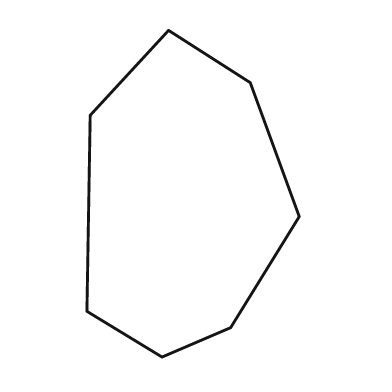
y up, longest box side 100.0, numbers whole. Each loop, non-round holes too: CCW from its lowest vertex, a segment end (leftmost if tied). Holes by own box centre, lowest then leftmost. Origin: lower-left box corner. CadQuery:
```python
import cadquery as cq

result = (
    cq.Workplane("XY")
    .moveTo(23.0, 0.0)
    .lineTo(44.0, 9.0)
    .lineTo(65.0, 43.0)
    .lineTo(50.0, 84.0)
    .lineTo(25.0, 100.0)
    .lineTo(1.0, 74.0)
    .lineTo(0.0, 14.0)
    .close()
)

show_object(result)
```